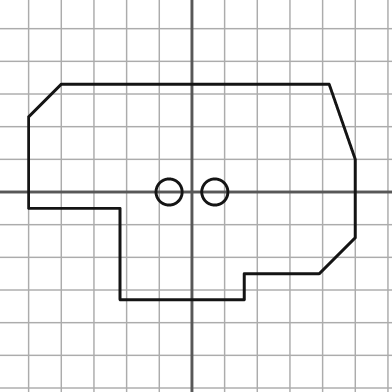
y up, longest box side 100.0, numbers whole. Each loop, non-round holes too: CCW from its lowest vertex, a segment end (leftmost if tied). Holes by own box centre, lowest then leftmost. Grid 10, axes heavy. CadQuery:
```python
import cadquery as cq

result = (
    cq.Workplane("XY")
    .moveTo(-22.0, -33.0)
    .lineTo(16.0, -33.0)
    .lineTo(16.0, -25.0)
    .lineTo(39.0, -25.0)
    .lineTo(50.0, -14.0)
    .lineTo(50.0, 10.0)
    .lineTo(42.0, 33.0)
    .lineTo(-40.0, 33.0)
    .lineTo(-50.0, 23.0)
    .lineTo(-50.0, -5.0)
    .lineTo(-22.0, -5.0)
    .close()
    .moveTo(-7.0, 0.0)
    .circle(4.0)
    .moveTo(7.0, 0.0)
    .circle(4.0)
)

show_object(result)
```